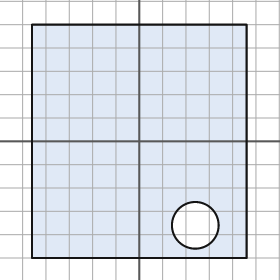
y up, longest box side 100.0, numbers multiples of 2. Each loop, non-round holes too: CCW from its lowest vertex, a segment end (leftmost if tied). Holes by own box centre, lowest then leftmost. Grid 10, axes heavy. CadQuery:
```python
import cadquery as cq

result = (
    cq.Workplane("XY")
    .moveTo(-46.0, -50.0)
    .lineTo(46.0, -50.0)
    .lineTo(46.0, 50.0)
    .lineTo(-46.0, 50.0)
    .close()
    .moveTo(24.0, -36.0)
    .circle(10.0)
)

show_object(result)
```